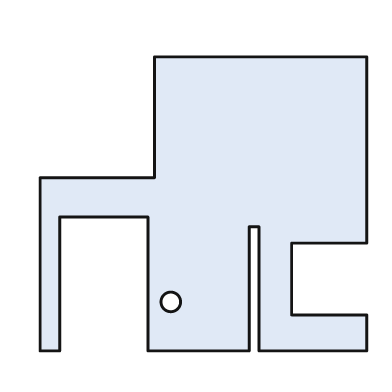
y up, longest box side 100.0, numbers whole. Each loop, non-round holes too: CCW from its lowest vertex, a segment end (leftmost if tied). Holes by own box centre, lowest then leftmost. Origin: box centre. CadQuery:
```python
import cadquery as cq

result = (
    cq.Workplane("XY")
    .moveTo(-50.0, -45.0)
    .lineTo(-44.0, -45.0)
    .lineTo(-44.0, -4.0)
    .lineTo(-17.0, -4.0)
    .lineTo(-17.0, -45.0)
    .lineTo(14.0, -45.0)
    .lineTo(14.0, -7.0)
    .lineTo(17.0, -7.0)
    .lineTo(17.0, -45.0)
    .lineTo(50.0, -45.0)
    .lineTo(50.0, -34.0)
    .lineTo(27.0, -34.0)
    .lineTo(27.0, -12.0)
    .lineTo(50.0, -12.0)
    .lineTo(50.0, 45.0)
    .lineTo(-15.0, 45.0)
    .lineTo(-15.0, 8.0)
    .lineTo(-50.0, 8.0)
    .close()
    .moveTo(-10.0, -30.0)
    .circle(3.0)
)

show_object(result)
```